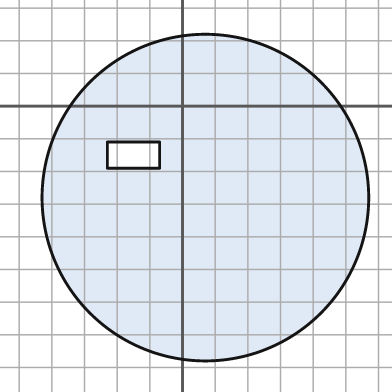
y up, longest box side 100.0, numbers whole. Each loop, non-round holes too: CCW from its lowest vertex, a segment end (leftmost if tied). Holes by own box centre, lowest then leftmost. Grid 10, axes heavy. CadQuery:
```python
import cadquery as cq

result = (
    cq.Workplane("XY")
    .moveTo(7.0, -28.0)
    .circle(50.0)
    .moveTo(-23.0, -19.0)
    .lineTo(-7.0, -19.0)
    .lineTo(-7.0, -11.0)
    .lineTo(-23.0, -11.0)
    .close()
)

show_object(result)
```